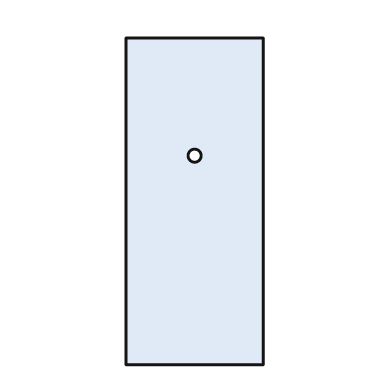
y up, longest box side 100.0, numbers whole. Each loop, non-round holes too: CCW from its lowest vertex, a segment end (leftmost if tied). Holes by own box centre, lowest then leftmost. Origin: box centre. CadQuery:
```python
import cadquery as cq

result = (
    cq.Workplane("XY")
    .moveTo(-21.0, -50.0)
    .lineTo(21.0, -50.0)
    .lineTo(21.0, 50.0)
    .lineTo(-21.0, 50.0)
    .close()
    .moveTo(0.0, 14.0)
    .circle(2.0)
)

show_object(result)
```